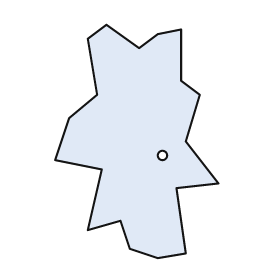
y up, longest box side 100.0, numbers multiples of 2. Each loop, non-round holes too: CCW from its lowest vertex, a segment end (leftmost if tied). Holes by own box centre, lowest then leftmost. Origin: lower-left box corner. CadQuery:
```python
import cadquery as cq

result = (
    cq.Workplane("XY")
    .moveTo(44.0, 0.0)
    .lineTo(56.0, 2.0)
    .lineTo(52.0, 30.0)
    .lineTo(70.0, 32.0)
    .lineTo(56.0, 50.0)
    .lineTo(62.0, 70.0)
    .lineTo(54.0, 76.0)
    .lineTo(54.0, 98.0)
    .lineTo(44.0, 96.0)
    .lineTo(36.0, 90.0)
    .lineTo(22.0, 100.0)
    .lineTo(14.0, 94.0)
    .lineTo(18.0, 70.0)
    .lineTo(6.0, 60.0)
    .lineTo(0.0, 42.0)
    .lineTo(20.0, 38.0)
    .lineTo(14.0, 12.0)
    .lineTo(28.0, 16.0)
    .lineTo(32.0, 4.0)
    .close()
    .moveTo(46.0, 44.0)
    .circle(2.0)
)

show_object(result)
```